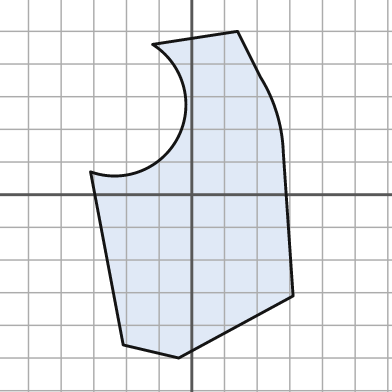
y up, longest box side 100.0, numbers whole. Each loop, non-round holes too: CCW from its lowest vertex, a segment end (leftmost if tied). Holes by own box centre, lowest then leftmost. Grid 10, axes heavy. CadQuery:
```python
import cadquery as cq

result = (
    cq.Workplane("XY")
    .moveTo(-4.0, -50.0)
    .lineTo(31.0, -31.0)
    .lineTo(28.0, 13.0)
    .threePointArc((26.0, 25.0), (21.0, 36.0))
    .lineTo(14.0, 50.0)
    .lineTo(-12.0, 46.0)
    .threePointArc((-4.0, 18.0), (-31.0, 7.0))
    .lineTo(-21.0, -46.0)
    .close()
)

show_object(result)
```